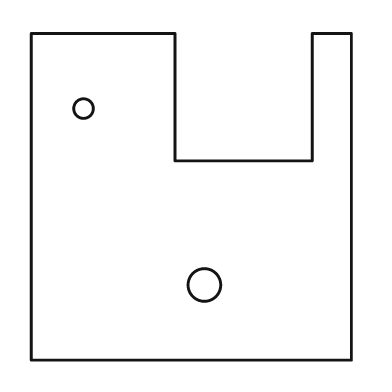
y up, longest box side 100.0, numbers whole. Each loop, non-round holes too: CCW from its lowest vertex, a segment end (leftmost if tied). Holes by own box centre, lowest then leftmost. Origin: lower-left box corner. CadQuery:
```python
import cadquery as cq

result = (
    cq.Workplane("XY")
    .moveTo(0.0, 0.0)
    .lineTo(98.0, 0.0)
    .lineTo(98.0, 100.0)
    .lineTo(86.0, 100.0)
    .lineTo(86.0, 61.0)
    .lineTo(44.0, 61.0)
    .lineTo(44.0, 100.0)
    .lineTo(0.0, 100.0)
    .close()
    .moveTo(53.0, 23.0)
    .circle(5.0)
    .moveTo(16.0, 77.0)
    .circle(3.0)
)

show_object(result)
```